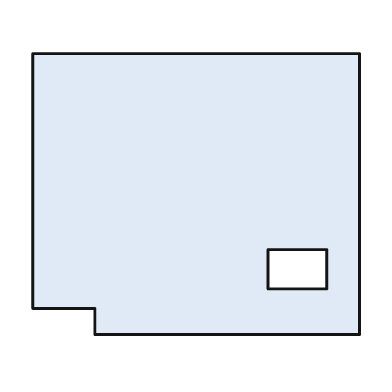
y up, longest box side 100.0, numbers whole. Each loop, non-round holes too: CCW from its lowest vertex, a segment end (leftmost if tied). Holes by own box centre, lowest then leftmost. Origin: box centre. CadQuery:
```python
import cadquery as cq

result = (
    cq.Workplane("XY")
    .moveTo(-31.0, -43.0)
    .lineTo(50.0, -43.0)
    .lineTo(50.0, 43.0)
    .lineTo(-50.0, 43.0)
    .lineTo(-50.0, -35.0)
    .lineTo(-31.0, -35.0)
    .close()
    .moveTo(22.0, -29.0)
    .lineTo(40.0, -29.0)
    .lineTo(40.0, -17.0)
    .lineTo(22.0, -17.0)
    .close()
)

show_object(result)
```